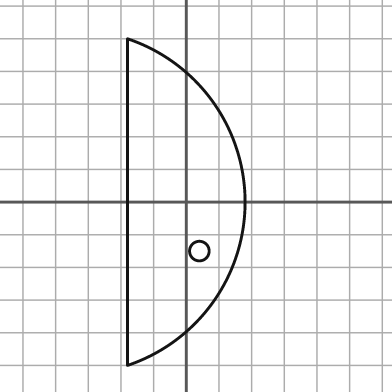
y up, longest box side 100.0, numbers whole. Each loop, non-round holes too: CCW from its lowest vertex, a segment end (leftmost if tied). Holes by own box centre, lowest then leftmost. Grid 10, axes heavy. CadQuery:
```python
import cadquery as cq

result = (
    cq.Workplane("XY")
    .moveTo(-18.0, -50.0)
    .threePointArc((18.0, 0.0), (-18.0, 50.0))
    .close()
    .moveTo(4.0, -15.0)
    .circle(3.0)
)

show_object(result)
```